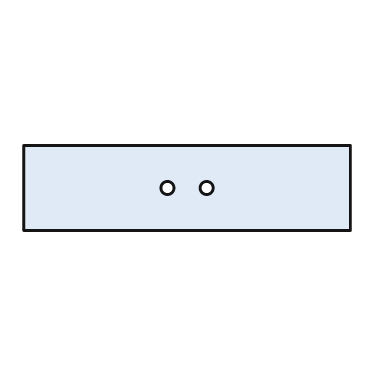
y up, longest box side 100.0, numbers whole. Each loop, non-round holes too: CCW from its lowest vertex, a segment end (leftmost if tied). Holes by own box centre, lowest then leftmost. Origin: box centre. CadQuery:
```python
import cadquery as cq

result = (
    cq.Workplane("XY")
    .moveTo(-50.0, -13.0)
    .lineTo(50.0, -13.0)
    .lineTo(50.0, 13.0)
    .lineTo(-50.0, 13.0)
    .close()
    .moveTo(-6.0, 0.0)
    .circle(2.0)
    .moveTo(6.0, 0.0)
    .circle(2.0)
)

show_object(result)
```